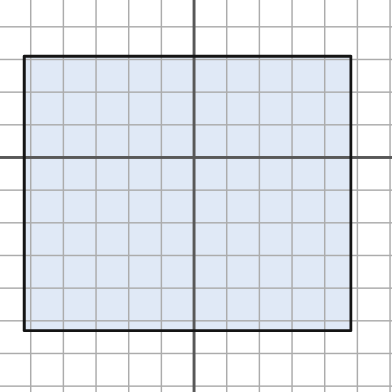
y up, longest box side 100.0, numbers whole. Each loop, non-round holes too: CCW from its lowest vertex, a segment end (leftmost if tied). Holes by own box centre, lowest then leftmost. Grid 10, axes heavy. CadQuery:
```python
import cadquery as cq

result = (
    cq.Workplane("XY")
    .moveTo(-52.0, -53.0)
    .lineTo(48.0, -53.0)
    .lineTo(48.0, 31.0)
    .lineTo(-52.0, 31.0)
    .close()
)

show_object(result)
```